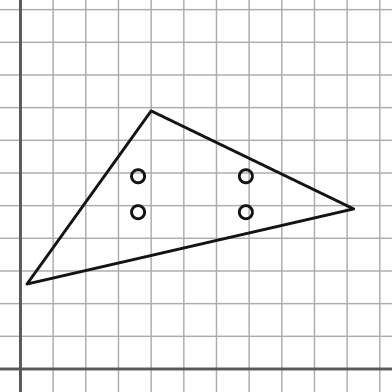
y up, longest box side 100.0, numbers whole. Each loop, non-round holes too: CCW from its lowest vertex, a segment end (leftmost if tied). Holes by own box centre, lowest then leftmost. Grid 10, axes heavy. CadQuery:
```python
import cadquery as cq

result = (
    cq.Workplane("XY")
    .moveTo(2.0, 26.0)
    .lineTo(102.0, 49.0)
    .lineTo(40.0, 79.0)
    .close()
    .moveTo(36.0, 48.0)
    .circle(2.0)
    .moveTo(69.0, 48.0)
    .circle(2.0)
    .moveTo(36.0, 59.0)
    .circle(2.0)
    .moveTo(69.0, 59.0)
    .circle(2.0)
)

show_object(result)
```